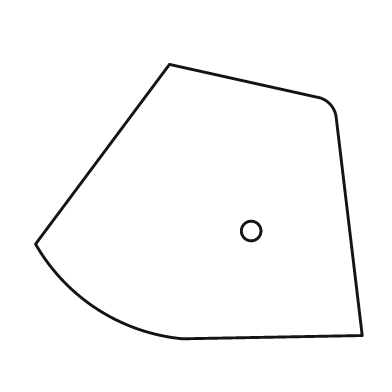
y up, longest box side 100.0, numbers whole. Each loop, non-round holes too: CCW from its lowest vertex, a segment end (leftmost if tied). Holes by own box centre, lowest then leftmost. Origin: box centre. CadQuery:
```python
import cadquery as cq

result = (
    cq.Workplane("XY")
    .moveTo(-5.0, -42.0)
    .lineTo(50.0, -41.0)
    .lineTo(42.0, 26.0)
    .threePointArc((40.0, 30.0), (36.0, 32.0))
    .lineTo(-9.0, 42.0)
    .lineTo(-50.0, -13.0)
    .threePointArc((-31.0, -33.0), (-5.0, -42.0))
    .close()
    .moveTo(16.0, -9.0)
    .circle(3.0)
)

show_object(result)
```